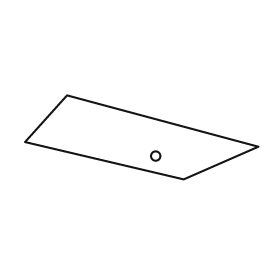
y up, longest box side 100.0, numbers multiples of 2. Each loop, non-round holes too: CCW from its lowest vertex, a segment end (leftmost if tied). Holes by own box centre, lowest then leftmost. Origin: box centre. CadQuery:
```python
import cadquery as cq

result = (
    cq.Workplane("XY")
    .moveTo(18.0, -18.0)
    .lineTo(50.0, -4.0)
    .lineTo(-32.0, 18.0)
    .lineTo(-50.0, -2.0)
    .close()
    .moveTo(6.0, -8.0)
    .circle(2.0)
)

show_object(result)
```